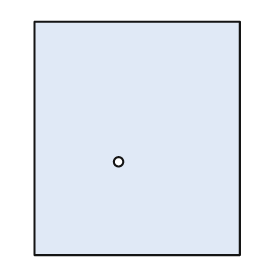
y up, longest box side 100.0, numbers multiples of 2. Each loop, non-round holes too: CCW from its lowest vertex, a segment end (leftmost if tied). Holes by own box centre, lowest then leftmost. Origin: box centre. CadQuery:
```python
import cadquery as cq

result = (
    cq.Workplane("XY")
    .moveTo(-44.0, -50.0)
    .lineTo(44.0, -50.0)
    .lineTo(44.0, 50.0)
    .lineTo(-44.0, 50.0)
    .close()
    .moveTo(-8.0, -10.0)
    .circle(2.0)
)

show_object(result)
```